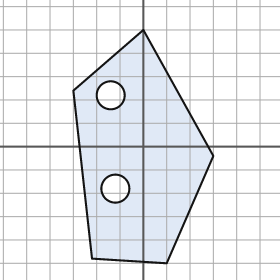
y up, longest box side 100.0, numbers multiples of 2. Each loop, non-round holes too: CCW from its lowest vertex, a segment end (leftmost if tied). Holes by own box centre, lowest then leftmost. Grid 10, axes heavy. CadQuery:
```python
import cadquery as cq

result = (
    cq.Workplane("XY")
    .moveTo(10.0, -50.0)
    .lineTo(30.0, -4.0)
    .lineTo(0.0, 50.0)
    .lineTo(-30.0, 24.0)
    .lineTo(-22.0, -48.0)
    .close()
    .moveTo(-12.0, -18.0)
    .circle(6.0)
    .moveTo(-14.0, 22.0)
    .circle(6.0)
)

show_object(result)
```